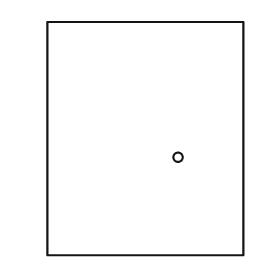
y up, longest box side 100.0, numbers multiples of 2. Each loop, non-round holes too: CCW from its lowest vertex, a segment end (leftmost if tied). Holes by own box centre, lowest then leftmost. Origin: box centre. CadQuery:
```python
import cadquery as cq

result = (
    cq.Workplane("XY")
    .moveTo(-42.0, -50.0)
    .lineTo(42.0, -50.0)
    .lineTo(42.0, 50.0)
    .lineTo(-42.0, 50.0)
    .close()
    .moveTo(14.0, -8.0)
    .circle(2.0)
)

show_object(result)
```